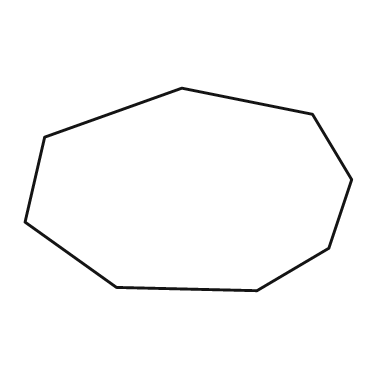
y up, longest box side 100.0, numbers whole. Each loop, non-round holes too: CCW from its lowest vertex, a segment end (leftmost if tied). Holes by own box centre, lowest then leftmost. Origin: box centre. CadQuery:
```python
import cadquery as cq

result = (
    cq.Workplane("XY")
    .moveTo(21.0, -31.0)
    .lineTo(43.0, -18.0)
    .lineTo(50.0, 3.0)
    .lineTo(38.0, 23.0)
    .lineTo(-2.0, 31.0)
    .lineTo(-44.0, 16.0)
    .lineTo(-50.0, -10.0)
    .lineTo(-22.0, -30.0)
    .close()
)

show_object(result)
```